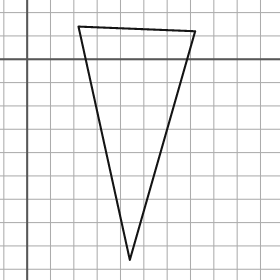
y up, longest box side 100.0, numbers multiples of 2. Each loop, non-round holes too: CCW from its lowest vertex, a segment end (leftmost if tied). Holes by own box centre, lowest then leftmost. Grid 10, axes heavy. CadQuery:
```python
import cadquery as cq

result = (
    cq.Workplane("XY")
    .moveTo(44.0, -86.0)
    .lineTo(72.0, 12.0)
    .lineTo(22.0, 14.0)
    .close()
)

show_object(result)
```